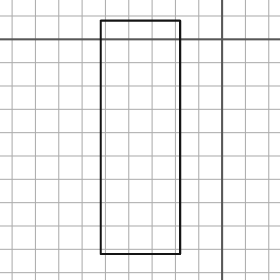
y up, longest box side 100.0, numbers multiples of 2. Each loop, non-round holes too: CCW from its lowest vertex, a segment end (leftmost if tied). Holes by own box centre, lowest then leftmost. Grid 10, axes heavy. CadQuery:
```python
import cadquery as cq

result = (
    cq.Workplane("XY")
    .moveTo(-52.0, -92.0)
    .lineTo(-18.0, -92.0)
    .lineTo(-18.0, 8.0)
    .lineTo(-52.0, 8.0)
    .close()
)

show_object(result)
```